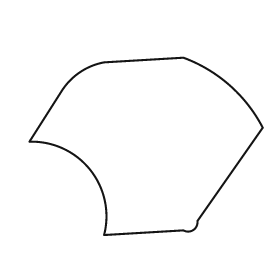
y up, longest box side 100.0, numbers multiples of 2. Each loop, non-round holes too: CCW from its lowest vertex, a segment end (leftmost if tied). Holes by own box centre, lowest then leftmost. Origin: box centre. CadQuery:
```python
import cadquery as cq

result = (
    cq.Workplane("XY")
    .moveTo(-18.0, -38.0)
    .lineTo(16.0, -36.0)
    .threePointArc((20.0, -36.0), (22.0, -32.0))
    .lineTo(50.0, 8.0)
    .threePointArc((36.0, 26.0), (16.0, 38.0))
    .lineTo(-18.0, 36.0)
    .threePointArc((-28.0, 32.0), (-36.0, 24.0))
    .lineTo(-50.0, 2.0)
    .threePointArc((-24.0, -10.0), (-18.0, -38.0))
    .close()
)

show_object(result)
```